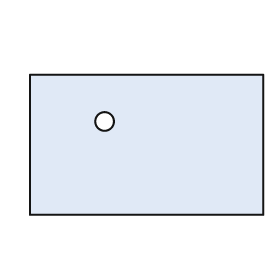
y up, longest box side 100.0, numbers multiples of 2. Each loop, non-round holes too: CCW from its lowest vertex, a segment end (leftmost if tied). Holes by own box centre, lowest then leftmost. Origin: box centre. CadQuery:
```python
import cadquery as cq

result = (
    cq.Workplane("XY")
    .moveTo(-50.0, -30.0)
    .lineTo(50.0, -30.0)
    .lineTo(50.0, 30.0)
    .lineTo(-50.0, 30.0)
    .close()
    .moveTo(-18.0, 10.0)
    .circle(4.0)
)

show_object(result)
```